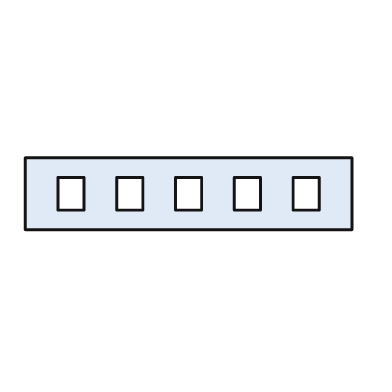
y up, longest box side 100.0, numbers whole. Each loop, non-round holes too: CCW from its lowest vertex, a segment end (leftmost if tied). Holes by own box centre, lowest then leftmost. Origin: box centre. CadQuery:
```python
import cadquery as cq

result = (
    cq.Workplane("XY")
    .moveTo(-50.0, -11.0)
    .lineTo(50.0, -11.0)
    .lineTo(50.0, 11.0)
    .lineTo(-50.0, 11.0)
    .close()
    .moveTo(-40.0, -5.0)
    .lineTo(-32.0, -5.0)
    .lineTo(-32.0, 5.0)
    .lineTo(-40.0, 5.0)
    .close()
    .moveTo(-22.0, -5.0)
    .lineTo(-14.0, -5.0)
    .lineTo(-14.0, 5.0)
    .lineTo(-22.0, 5.0)
    .close()
    .moveTo(-4.0, -5.0)
    .lineTo(4.0, -5.0)
    .lineTo(4.0, 5.0)
    .lineTo(-4.0, 5.0)
    .close()
    .moveTo(14.0, -5.0)
    .lineTo(22.0, -5.0)
    .lineTo(22.0, 5.0)
    .lineTo(14.0, 5.0)
    .close()
    .moveTo(32.0, -5.0)
    .lineTo(40.0, -5.0)
    .lineTo(40.0, 5.0)
    .lineTo(32.0, 5.0)
    .close()
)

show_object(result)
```